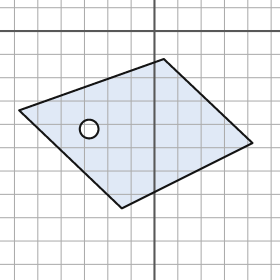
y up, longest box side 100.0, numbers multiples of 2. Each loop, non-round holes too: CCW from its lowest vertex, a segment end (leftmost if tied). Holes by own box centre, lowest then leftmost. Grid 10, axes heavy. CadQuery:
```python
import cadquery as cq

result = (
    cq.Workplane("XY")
    .moveTo(-14.0, -76.0)
    .lineTo(42.0, -48.0)
    .lineTo(4.0, -12.0)
    .lineTo(-58.0, -34.0)
    .close()
    .moveTo(-28.0, -42.0)
    .circle(4.0)
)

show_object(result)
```